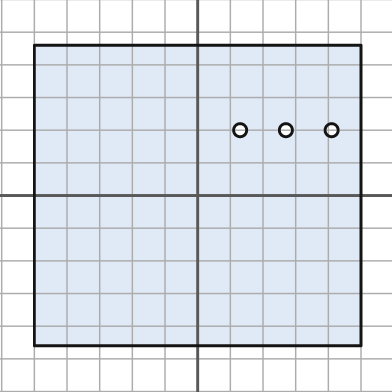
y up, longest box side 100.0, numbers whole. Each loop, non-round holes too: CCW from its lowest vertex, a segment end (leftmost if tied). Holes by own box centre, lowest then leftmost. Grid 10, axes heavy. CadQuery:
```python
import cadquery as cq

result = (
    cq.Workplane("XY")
    .moveTo(-50.0, -46.0)
    .lineTo(50.0, -46.0)
    .lineTo(50.0, 46.0)
    .lineTo(-50.0, 46.0)
    .close()
    .moveTo(13.0, 20.0)
    .circle(2.0)
    .moveTo(27.0, 20.0)
    .circle(2.0)
    .moveTo(41.0, 20.0)
    .circle(2.0)
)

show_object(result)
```